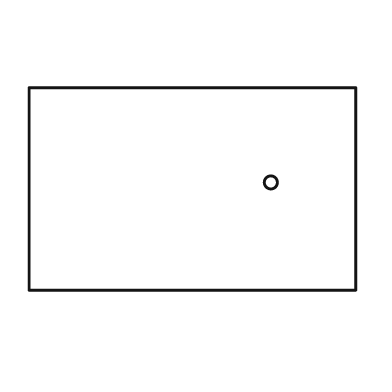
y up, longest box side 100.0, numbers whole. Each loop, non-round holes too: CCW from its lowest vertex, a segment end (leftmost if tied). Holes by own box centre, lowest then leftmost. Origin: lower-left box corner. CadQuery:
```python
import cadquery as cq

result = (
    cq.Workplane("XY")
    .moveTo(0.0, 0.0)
    .lineTo(100.0, 0.0)
    .lineTo(100.0, 62.0)
    .lineTo(0.0, 62.0)
    .close()
    .moveTo(74.0, 33.0)
    .circle(2.0)
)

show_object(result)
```